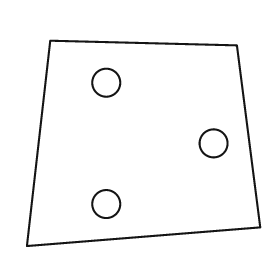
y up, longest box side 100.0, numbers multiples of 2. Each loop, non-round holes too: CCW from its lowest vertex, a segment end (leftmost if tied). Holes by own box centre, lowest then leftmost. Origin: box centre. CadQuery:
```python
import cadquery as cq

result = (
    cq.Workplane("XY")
    .moveTo(-50.0, -44.0)
    .lineTo(50.0, -36.0)
    .lineTo(40.0, 42.0)
    .lineTo(-40.0, 44.0)
    .close()
    .moveTo(-16.0, -26.0)
    .circle(6.0)
    .moveTo(30.0, 0.0)
    .circle(6.0)
    .moveTo(-16.0, 26.0)
    .circle(6.0)
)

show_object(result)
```